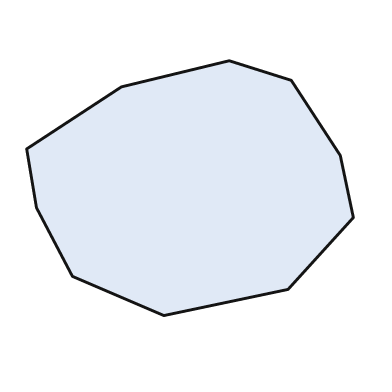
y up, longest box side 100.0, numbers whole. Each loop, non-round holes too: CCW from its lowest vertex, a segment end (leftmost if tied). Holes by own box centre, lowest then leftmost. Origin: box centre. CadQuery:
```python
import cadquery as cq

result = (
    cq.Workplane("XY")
    .moveTo(-8.0, -39.0)
    .lineTo(30.0, -31.0)
    .lineTo(50.0, -9.0)
    .lineTo(46.0, 10.0)
    .lineTo(31.0, 33.0)
    .lineTo(12.0, 39.0)
    .lineTo(-21.0, 31.0)
    .lineTo(-50.0, 12.0)
    .lineTo(-47.0, -6.0)
    .lineTo(-36.0, -27.0)
    .close()
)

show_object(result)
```